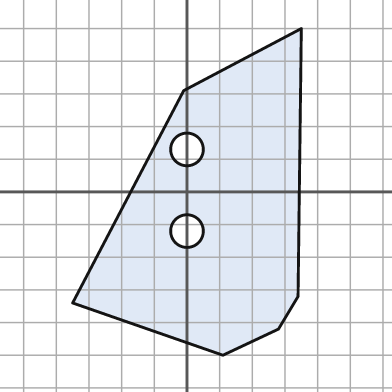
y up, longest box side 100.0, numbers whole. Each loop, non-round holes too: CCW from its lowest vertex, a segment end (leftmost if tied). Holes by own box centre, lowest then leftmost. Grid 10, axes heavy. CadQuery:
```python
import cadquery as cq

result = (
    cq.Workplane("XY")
    .moveTo(11.0, -50.0)
    .lineTo(28.0, -42.0)
    .lineTo(34.0, -32.0)
    .lineTo(35.0, 50.0)
    .lineTo(-1.0, 31.0)
    .lineTo(-35.0, -34.0)
    .close()
    .moveTo(0.0, -12.0)
    .circle(5.0)
    .moveTo(0.0, 13.0)
    .circle(5.0)
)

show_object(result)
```